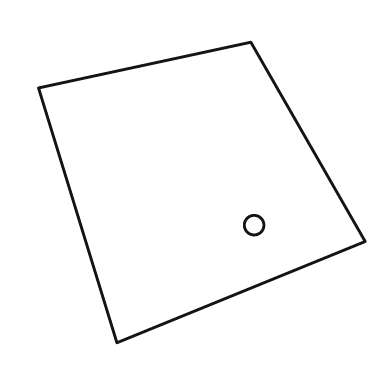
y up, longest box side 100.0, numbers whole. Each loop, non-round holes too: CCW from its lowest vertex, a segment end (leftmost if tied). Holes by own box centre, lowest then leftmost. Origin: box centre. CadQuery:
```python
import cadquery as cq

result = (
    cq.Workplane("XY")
    .moveTo(-26.0, -46.0)
    .lineTo(50.0, -15.0)
    .lineTo(15.0, 46.0)
    .lineTo(-50.0, 32.0)
    .close()
    .moveTo(16.0, -10.0)
    .circle(3.0)
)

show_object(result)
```